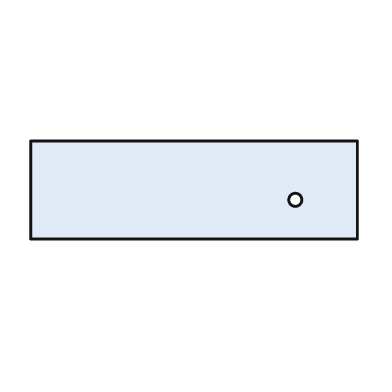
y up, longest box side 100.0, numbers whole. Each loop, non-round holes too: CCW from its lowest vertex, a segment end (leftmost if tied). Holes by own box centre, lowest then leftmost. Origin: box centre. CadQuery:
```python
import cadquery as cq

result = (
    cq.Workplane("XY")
    .moveTo(-50.0, -15.0)
    .lineTo(50.0, -15.0)
    .lineTo(50.0, 15.0)
    .lineTo(-50.0, 15.0)
    .close()
    .moveTo(31.0, -3.0)
    .circle(2.0)
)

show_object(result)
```